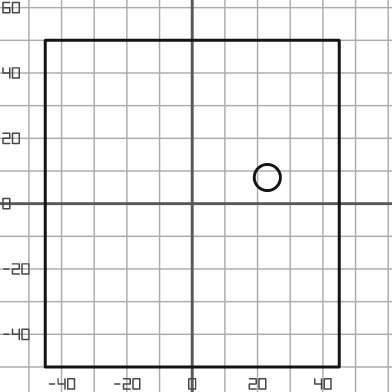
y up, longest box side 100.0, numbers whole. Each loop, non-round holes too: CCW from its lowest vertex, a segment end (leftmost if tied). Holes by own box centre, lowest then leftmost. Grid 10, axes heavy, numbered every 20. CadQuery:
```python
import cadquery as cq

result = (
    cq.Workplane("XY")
    .moveTo(-45.0, -50.0)
    .lineTo(45.0, -50.0)
    .lineTo(45.0, 50.0)
    .lineTo(-45.0, 50.0)
    .close()
    .moveTo(23.0, 8.0)
    .circle(4.0)
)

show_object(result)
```